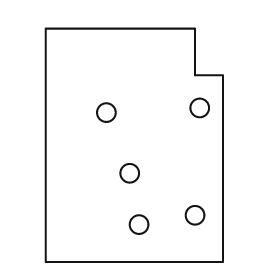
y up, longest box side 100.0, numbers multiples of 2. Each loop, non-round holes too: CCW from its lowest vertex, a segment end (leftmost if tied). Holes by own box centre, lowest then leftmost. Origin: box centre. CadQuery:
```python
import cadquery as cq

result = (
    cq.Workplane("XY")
    .moveTo(-38.0, -50.0)
    .lineTo(38.0, -50.0)
    .lineTo(38.0, 30.0)
    .lineTo(26.0, 30.0)
    .lineTo(26.0, 50.0)
    .lineTo(-38.0, 50.0)
    .close()
    .moveTo(2.0, -34.0)
    .circle(4.0)
    .moveTo(26.0, -30.0)
    .circle(4.0)
    .moveTo(-2.0, -12.0)
    .circle(4.0)
    .moveTo(-12.0, 14.0)
    .circle(4.0)
    .moveTo(28.0, 16.0)
    .circle(4.0)
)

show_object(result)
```